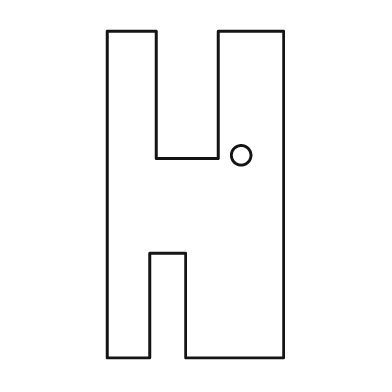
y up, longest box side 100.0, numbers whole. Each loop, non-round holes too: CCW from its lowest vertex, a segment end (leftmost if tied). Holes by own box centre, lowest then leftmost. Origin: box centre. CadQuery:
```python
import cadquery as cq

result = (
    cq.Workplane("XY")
    .moveTo(-27.0, -50.0)
    .lineTo(-14.0, -50.0)
    .lineTo(-14.0, -18.0)
    .lineTo(-3.0, -18.0)
    .lineTo(-3.0, -50.0)
    .lineTo(27.0, -50.0)
    .lineTo(27.0, 50.0)
    .lineTo(7.0, 50.0)
    .lineTo(7.0, 11.0)
    .lineTo(-12.0, 11.0)
    .lineTo(-12.0, 50.0)
    .lineTo(-27.0, 50.0)
    .close()
    .moveTo(14.0, 12.0)
    .circle(3.0)
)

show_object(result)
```